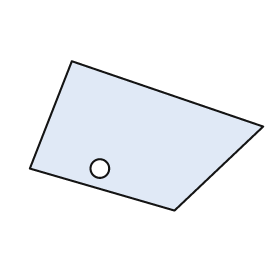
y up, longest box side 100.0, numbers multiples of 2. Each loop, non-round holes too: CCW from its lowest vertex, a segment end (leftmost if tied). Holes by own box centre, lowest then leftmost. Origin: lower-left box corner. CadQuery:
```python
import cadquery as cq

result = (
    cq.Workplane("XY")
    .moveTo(62.0, 0.0)
    .lineTo(100.0, 36.0)
    .lineTo(18.0, 64.0)
    .lineTo(0.0, 18.0)
    .close()
    .moveTo(30.0, 18.0)
    .circle(4.0)
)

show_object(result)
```